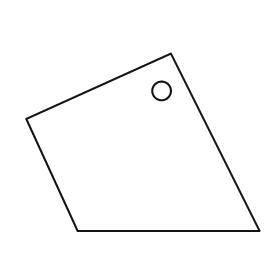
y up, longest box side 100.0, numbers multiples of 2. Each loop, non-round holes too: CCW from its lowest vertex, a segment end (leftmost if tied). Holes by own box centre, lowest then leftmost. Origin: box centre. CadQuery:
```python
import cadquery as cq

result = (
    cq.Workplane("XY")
    .moveTo(-28.0, -38.0)
    .lineTo(50.0, -38.0)
    .lineTo(12.0, 38.0)
    .lineTo(-50.0, 10.0)
    .close()
    .moveTo(8.0, 22.0)
    .circle(4.0)
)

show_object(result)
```